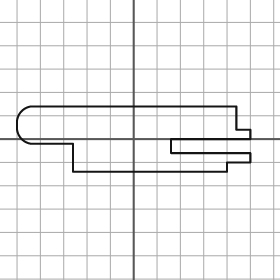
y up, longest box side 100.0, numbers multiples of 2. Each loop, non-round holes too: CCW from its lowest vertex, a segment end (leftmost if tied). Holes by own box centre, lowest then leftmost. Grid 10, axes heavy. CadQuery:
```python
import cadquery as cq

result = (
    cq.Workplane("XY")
    .moveTo(-26.0, -14.0)
    .lineTo(40.0, -14.0)
    .lineTo(40.0, -10.0)
    .lineTo(50.0, -10.0)
    .lineTo(50.0, -6.0)
    .lineTo(16.0, -6.0)
    .lineTo(16.0, 0.0)
    .lineTo(50.0, 0.0)
    .lineTo(50.0, 4.0)
    .lineTo(44.0, 4.0)
    .lineTo(44.0, 14.0)
    .lineTo(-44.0, 14.0)
    .threePointArc((-48.0, 12.0), (-50.0, 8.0))
    .lineTo(-50.0, 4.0)
    .threePointArc((-48.0, 0.0), (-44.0, -2.0))
    .lineTo(-26.0, -2.0)
    .close()
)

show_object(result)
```